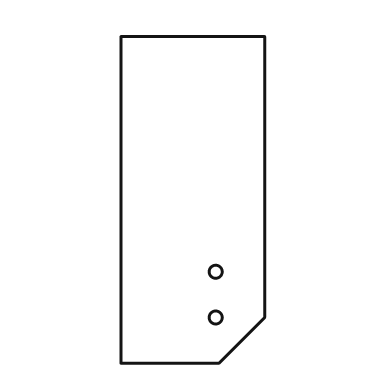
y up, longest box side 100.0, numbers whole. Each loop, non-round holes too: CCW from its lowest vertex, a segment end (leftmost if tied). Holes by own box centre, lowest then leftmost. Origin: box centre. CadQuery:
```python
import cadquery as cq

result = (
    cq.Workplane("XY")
    .moveTo(-22.0, -50.0)
    .lineTo(8.0, -50.0)
    .lineTo(22.0, -36.0)
    .lineTo(22.0, 50.0)
    .lineTo(-22.0, 50.0)
    .close()
    .moveTo(7.0, -36.0)
    .circle(2.0)
    .moveTo(7.0, -22.0)
    .circle(2.0)
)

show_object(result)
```